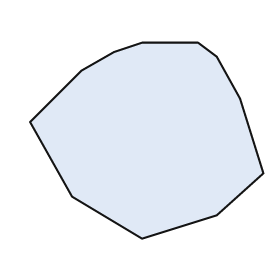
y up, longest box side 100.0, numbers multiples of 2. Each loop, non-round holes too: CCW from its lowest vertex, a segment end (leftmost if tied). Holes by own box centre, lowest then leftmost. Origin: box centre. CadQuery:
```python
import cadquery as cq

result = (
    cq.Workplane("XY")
    .moveTo(-2.0, -42.0)
    .lineTo(30.0, -32.0)
    .lineTo(50.0, -14.0)
    .lineTo(40.0, 18.0)
    .lineTo(30.0, 36.0)
    .lineTo(22.0, 42.0)
    .lineTo(-2.0, 42.0)
    .lineTo(-14.0, 38.0)
    .lineTo(-28.0, 30.0)
    .lineTo(-50.0, 8.0)
    .lineTo(-32.0, -24.0)
    .close()
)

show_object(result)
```